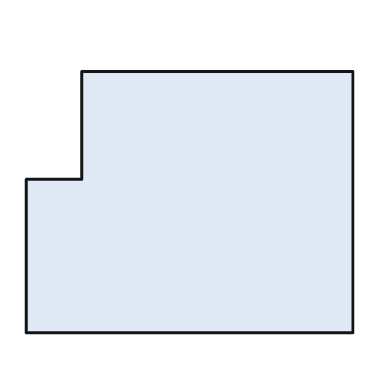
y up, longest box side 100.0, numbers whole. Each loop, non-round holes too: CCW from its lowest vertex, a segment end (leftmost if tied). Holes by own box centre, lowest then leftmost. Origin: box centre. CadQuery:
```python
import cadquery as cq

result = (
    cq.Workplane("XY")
    .moveTo(-50.0, -40.0)
    .lineTo(50.0, -40.0)
    .lineTo(50.0, 40.0)
    .lineTo(-33.0, 40.0)
    .lineTo(-33.0, 7.0)
    .lineTo(-50.0, 7.0)
    .close()
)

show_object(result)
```